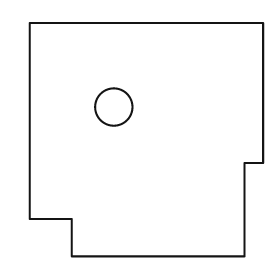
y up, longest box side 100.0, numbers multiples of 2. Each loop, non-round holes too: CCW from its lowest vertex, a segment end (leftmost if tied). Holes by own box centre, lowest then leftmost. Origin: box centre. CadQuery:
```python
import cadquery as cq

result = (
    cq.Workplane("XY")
    .moveTo(-32.0, -50.0)
    .lineTo(42.0, -50.0)
    .lineTo(42.0, -10.0)
    .lineTo(50.0, -10.0)
    .lineTo(50.0, 50.0)
    .lineTo(-50.0, 50.0)
    .lineTo(-50.0, -34.0)
    .lineTo(-32.0, -34.0)
    .close()
    .moveTo(-14.0, 14.0)
    .circle(8.0)
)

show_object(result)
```